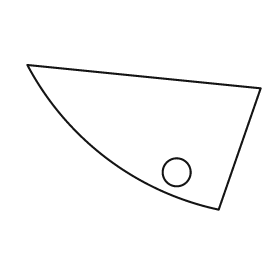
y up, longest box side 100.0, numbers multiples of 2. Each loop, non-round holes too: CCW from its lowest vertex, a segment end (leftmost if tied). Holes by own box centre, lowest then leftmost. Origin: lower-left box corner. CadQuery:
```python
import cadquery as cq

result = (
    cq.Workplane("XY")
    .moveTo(82.0, 0.0)
    .lineTo(100.0, 52.0)
    .lineTo(0.0, 62.0)
    .threePointArc((34.0, 22.0), (82.0, 0.0))
    .close()
    .moveTo(64.0, 16.0)
    .circle(6.0)
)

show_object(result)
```